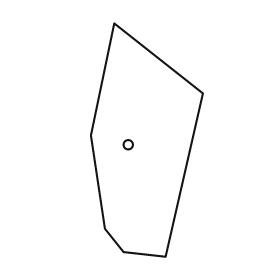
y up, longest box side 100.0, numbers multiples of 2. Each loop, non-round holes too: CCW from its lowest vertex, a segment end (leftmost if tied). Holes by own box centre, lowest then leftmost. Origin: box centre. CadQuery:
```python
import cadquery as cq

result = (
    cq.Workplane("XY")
    .moveTo(8.0, -50.0)
    .lineTo(24.0, 20.0)
    .lineTo(-14.0, 50.0)
    .lineTo(-24.0, 2.0)
    .lineTo(-18.0, -38.0)
    .lineTo(-10.0, -48.0)
    .close()
    .moveTo(-8.0, -2.0)
    .circle(2.0)
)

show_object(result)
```